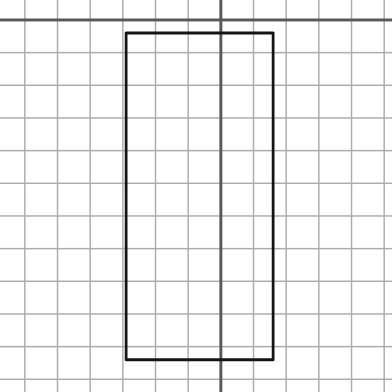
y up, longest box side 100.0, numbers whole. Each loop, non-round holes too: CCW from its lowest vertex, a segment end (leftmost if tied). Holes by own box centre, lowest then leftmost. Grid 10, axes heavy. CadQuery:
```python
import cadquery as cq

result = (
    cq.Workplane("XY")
    .moveTo(-29.0, -104.0)
    .lineTo(16.0, -104.0)
    .lineTo(16.0, -4.0)
    .lineTo(-29.0, -4.0)
    .close()
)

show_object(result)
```